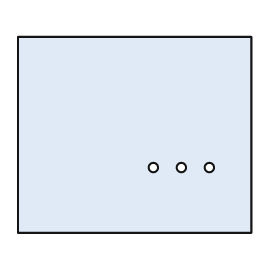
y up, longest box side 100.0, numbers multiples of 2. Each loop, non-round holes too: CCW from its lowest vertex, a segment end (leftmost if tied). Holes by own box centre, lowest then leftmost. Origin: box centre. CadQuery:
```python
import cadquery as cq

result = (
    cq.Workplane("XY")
    .moveTo(-50.0, -42.0)
    .lineTo(50.0, -42.0)
    .lineTo(50.0, 42.0)
    .lineTo(-50.0, 42.0)
    .close()
    .moveTo(8.0, -14.0)
    .circle(2.0)
    .moveTo(20.0, -14.0)
    .circle(2.0)
    .moveTo(32.0, -14.0)
    .circle(2.0)
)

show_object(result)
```